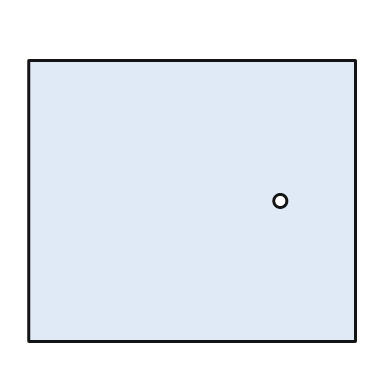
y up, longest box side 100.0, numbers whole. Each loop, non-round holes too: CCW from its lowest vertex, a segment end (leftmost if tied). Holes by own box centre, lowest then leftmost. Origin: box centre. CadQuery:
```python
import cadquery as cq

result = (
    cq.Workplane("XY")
    .moveTo(-50.0, -43.0)
    .lineTo(50.0, -43.0)
    .lineTo(50.0, 43.0)
    .lineTo(-50.0, 43.0)
    .close()
    .moveTo(27.0, 0.0)
    .circle(2.0)
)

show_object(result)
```